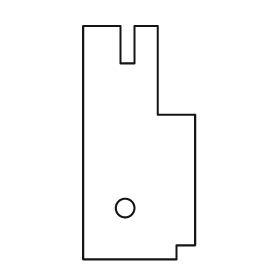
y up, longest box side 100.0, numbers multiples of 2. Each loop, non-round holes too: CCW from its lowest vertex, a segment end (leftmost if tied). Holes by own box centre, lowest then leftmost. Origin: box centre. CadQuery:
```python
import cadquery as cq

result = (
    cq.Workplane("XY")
    .moveTo(-24.0, -50.0)
    .lineTo(16.0, -50.0)
    .lineTo(16.0, -44.0)
    .lineTo(24.0, -44.0)
    .lineTo(24.0, 12.0)
    .lineTo(8.0, 12.0)
    .lineTo(8.0, 50.0)
    .lineTo(-2.0, 50.0)
    .lineTo(-2.0, 34.0)
    .lineTo(-8.0, 34.0)
    .lineTo(-8.0, 50.0)
    .lineTo(-24.0, 50.0)
    .close()
    .moveTo(-6.0, -28.0)
    .circle(4.0)
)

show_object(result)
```